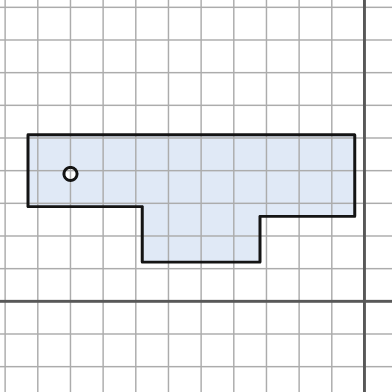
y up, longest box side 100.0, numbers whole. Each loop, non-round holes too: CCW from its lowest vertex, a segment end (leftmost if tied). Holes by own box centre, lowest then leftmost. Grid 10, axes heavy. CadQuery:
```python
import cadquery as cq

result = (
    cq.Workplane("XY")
    .moveTo(-68.0, 12.0)
    .lineTo(-32.0, 12.0)
    .lineTo(-32.0, 26.0)
    .lineTo(-3.0, 26.0)
    .lineTo(-3.0, 51.0)
    .lineTo(-103.0, 51.0)
    .lineTo(-103.0, 29.0)
    .lineTo(-68.0, 29.0)
    .close()
    .moveTo(-90.0, 39.0)
    .circle(2.0)
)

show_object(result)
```